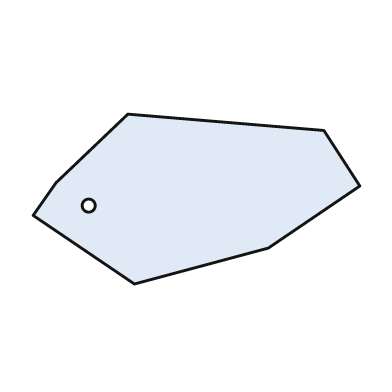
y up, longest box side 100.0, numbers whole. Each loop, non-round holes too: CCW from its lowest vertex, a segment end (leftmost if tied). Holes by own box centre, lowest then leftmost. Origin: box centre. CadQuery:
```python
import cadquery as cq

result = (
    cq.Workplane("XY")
    .moveTo(-19.0, -26.0)
    .lineTo(22.0, -15.0)
    .lineTo(50.0, 4.0)
    .lineTo(39.0, 21.0)
    .lineTo(-21.0, 26.0)
    .lineTo(-43.0, 5.0)
    .lineTo(-50.0, -5.0)
    .close()
    .moveTo(-33.0, -2.0)
    .circle(2.0)
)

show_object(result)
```